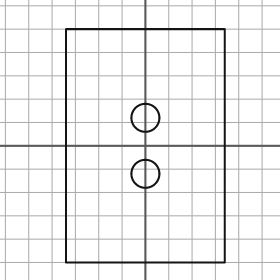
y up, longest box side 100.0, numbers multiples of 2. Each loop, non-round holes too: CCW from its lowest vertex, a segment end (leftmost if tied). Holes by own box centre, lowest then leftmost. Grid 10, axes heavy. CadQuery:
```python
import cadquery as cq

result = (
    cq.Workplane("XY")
    .moveTo(-34.0, -50.0)
    .lineTo(34.0, -50.0)
    .lineTo(34.0, 50.0)
    .lineTo(-34.0, 50.0)
    .close()
    .moveTo(0.0, -12.0)
    .circle(6.0)
    .moveTo(0.0, 12.0)
    .circle(6.0)
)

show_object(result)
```